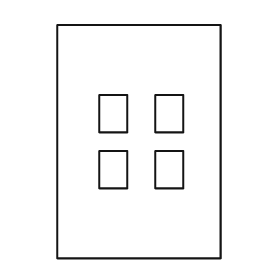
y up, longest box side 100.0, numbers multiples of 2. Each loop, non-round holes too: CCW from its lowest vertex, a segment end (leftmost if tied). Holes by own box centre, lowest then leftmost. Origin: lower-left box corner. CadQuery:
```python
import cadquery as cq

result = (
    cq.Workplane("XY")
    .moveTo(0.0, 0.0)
    .lineTo(70.0, 0.0)
    .lineTo(70.0, 100.0)
    .lineTo(0.0, 100.0)
    .close()
    .moveTo(18.0, 30.0)
    .lineTo(30.0, 30.0)
    .lineTo(30.0, 46.0)
    .lineTo(18.0, 46.0)
    .close()
    .moveTo(42.0, 30.0)
    .lineTo(54.0, 30.0)
    .lineTo(54.0, 46.0)
    .lineTo(42.0, 46.0)
    .close()
    .moveTo(18.0, 54.0)
    .lineTo(30.0, 54.0)
    .lineTo(30.0, 70.0)
    .lineTo(18.0, 70.0)
    .close()
    .moveTo(42.0, 54.0)
    .lineTo(54.0, 54.0)
    .lineTo(54.0, 70.0)
    .lineTo(42.0, 70.0)
    .close()
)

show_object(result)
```